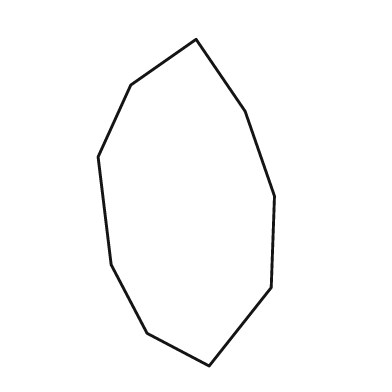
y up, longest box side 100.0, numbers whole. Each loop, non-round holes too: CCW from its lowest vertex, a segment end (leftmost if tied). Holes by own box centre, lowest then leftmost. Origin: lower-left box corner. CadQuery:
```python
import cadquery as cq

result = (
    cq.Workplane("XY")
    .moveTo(34.0, 0.0)
    .lineTo(53.0, 24.0)
    .lineTo(54.0, 52.0)
    .lineTo(45.0, 78.0)
    .lineTo(30.0, 100.0)
    .lineTo(10.0, 86.0)
    .lineTo(0.0, 64.0)
    .lineTo(4.0, 31.0)
    .lineTo(15.0, 10.0)
    .close()
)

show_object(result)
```